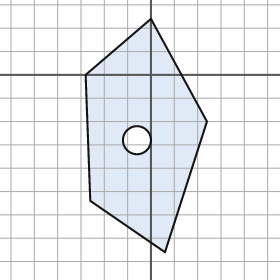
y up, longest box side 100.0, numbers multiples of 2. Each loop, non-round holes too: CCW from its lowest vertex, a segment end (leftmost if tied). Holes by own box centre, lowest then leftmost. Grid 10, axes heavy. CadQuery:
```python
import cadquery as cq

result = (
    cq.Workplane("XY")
    .moveTo(6.0, -76.0)
    .lineTo(24.0, -20.0)
    .lineTo(0.0, 24.0)
    .lineTo(-28.0, 0.0)
    .lineTo(-26.0, -54.0)
    .close()
    .moveTo(-6.0, -28.0)
    .circle(6.0)
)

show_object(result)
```